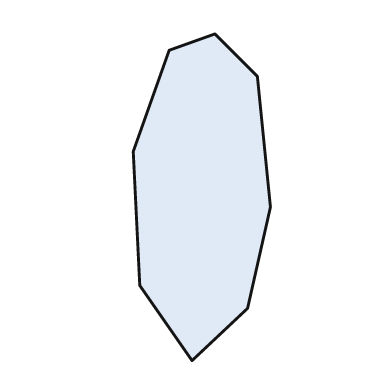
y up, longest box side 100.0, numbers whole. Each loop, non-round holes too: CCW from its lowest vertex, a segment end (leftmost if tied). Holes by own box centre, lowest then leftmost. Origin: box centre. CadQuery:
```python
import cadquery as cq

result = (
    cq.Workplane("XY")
    .moveTo(-3.0, -50.0)
    .lineTo(14.0, -34.0)
    .lineTo(21.0, -3.0)
    .lineTo(17.0, 37.0)
    .lineTo(4.0, 50.0)
    .lineTo(-10.0, 45.0)
    .lineTo(-21.0, 14.0)
    .lineTo(-19.0, -27.0)
    .close()
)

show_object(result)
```